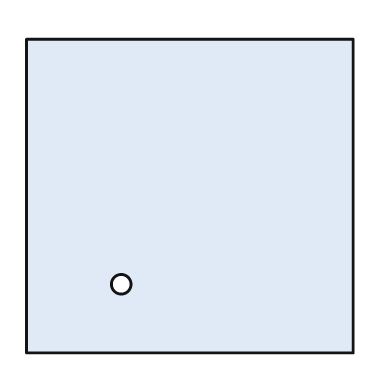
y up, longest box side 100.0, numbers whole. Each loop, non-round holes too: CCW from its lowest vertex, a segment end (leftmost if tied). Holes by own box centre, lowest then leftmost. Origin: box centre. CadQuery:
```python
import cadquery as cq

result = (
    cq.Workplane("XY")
    .moveTo(-50.0, -48.0)
    .lineTo(50.0, -48.0)
    .lineTo(50.0, 48.0)
    .lineTo(-50.0, 48.0)
    .close()
    .moveTo(-21.0, -27.0)
    .circle(3.0)
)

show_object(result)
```